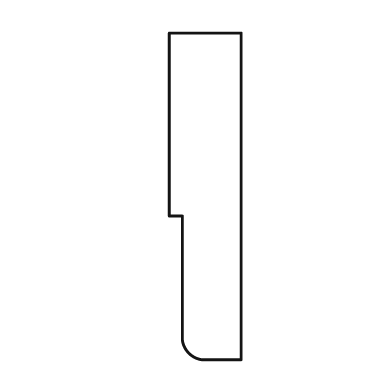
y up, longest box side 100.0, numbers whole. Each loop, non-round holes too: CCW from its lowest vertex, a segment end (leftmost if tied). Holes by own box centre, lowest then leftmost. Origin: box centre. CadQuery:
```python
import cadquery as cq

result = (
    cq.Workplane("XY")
    .moveTo(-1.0, -50.0)
    .lineTo(11.0, -50.0)
    .lineTo(11.0, 50.0)
    .lineTo(-11.0, 50.0)
    .lineTo(-11.0, -6.0)
    .lineTo(-7.0, -6.0)
    .lineTo(-7.0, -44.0)
    .threePointArc((-5.0, -48.0), (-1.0, -50.0))
    .close()
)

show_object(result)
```